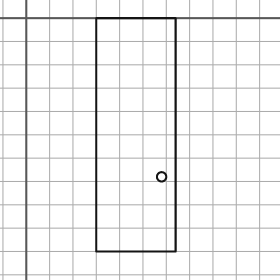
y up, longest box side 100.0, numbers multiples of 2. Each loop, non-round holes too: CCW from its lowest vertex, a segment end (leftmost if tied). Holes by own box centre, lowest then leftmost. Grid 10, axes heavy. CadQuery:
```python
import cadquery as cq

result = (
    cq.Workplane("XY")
    .moveTo(30.0, -100.0)
    .lineTo(64.0, -100.0)
    .lineTo(64.0, 0.0)
    .lineTo(30.0, 0.0)
    .close()
    .moveTo(58.0, -68.0)
    .circle(2.0)
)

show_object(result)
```